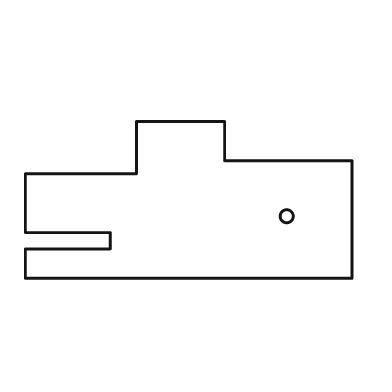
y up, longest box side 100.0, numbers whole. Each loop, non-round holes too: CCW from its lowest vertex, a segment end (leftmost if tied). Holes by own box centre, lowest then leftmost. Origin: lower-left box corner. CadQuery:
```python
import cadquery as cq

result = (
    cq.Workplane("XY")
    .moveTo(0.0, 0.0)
    .lineTo(100.0, 0.0)
    .lineTo(100.0, 36.0)
    .lineTo(61.0, 36.0)
    .lineTo(61.0, 48.0)
    .lineTo(34.0, 48.0)
    .lineTo(34.0, 32.0)
    .lineTo(0.0, 32.0)
    .lineTo(0.0, 14.0)
    .lineTo(26.0, 14.0)
    .lineTo(26.0, 9.0)
    .lineTo(0.0, 9.0)
    .close()
    .moveTo(80.0, 19.0)
    .circle(2.0)
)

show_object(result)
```